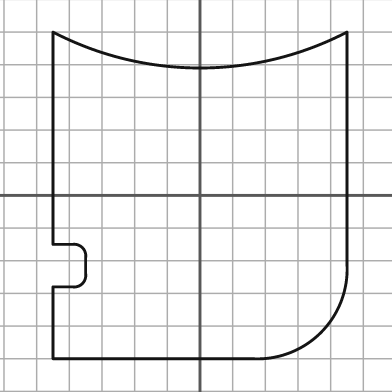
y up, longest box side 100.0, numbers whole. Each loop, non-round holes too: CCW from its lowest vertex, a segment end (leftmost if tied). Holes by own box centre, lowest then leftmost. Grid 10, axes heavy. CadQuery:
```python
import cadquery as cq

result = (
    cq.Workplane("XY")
    .moveTo(-45.0, -50.0)
    .lineTo(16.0, -50.0)
    .threePointArc((37.0, -42.0), (45.0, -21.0))
    .lineTo(45.0, 50.0)
    .threePointArc((0.0, 39.0), (-45.0, 50.0))
    .lineTo(-45.0, -15.0)
    .lineTo(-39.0, -15.0)
    .threePointArc((-36.0, -16.0), (-35.0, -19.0))
    .lineTo(-35.0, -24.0)
    .threePointArc((-36.0, -27.0), (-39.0, -28.0))
    .lineTo(-45.0, -28.0)
    .close()
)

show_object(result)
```